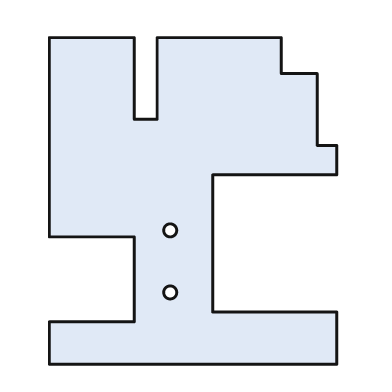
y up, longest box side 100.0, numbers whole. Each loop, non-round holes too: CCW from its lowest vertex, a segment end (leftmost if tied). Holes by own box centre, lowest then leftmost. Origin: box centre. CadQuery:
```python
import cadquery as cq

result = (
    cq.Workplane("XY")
    .moveTo(-44.0, -50.0)
    .lineTo(44.0, -50.0)
    .lineTo(44.0, -34.0)
    .lineTo(6.0, -34.0)
    .lineTo(6.0, 8.0)
    .lineTo(44.0, 8.0)
    .lineTo(44.0, 17.0)
    .lineTo(38.0, 17.0)
    .lineTo(38.0, 39.0)
    .lineTo(27.0, 39.0)
    .lineTo(27.0, 50.0)
    .lineTo(-11.0, 50.0)
    .lineTo(-11.0, 25.0)
    .lineTo(-18.0, 25.0)
    .lineTo(-18.0, 50.0)
    .lineTo(-44.0, 50.0)
    .lineTo(-44.0, -11.0)
    .lineTo(-18.0, -11.0)
    .lineTo(-18.0, -37.0)
    .lineTo(-44.0, -37.0)
    .close()
    .moveTo(-7.0, -28.0)
    .circle(2.0)
    .moveTo(-7.0, -9.0)
    .circle(2.0)
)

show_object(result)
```